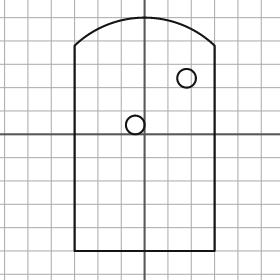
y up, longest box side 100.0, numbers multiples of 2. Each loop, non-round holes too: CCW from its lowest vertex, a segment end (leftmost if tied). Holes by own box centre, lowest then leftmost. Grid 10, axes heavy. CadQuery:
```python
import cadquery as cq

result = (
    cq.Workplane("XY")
    .moveTo(-30.0, -50.0)
    .lineTo(30.0, -50.0)
    .lineTo(30.0, 38.0)
    .threePointArc((0.0, 50.0), (-30.0, 38.0))
    .close()
    .moveTo(-4.0, 4.0)
    .circle(4.0)
    .moveTo(18.0, 24.0)
    .circle(4.0)
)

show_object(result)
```